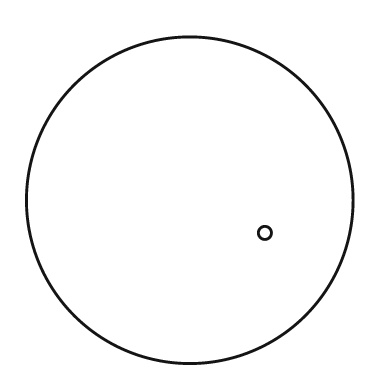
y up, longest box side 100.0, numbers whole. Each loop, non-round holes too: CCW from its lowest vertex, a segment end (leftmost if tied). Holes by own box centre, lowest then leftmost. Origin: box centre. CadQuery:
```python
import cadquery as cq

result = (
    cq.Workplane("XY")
    .moveTo(0.0, 0.0)
    .circle(50.0)
    .moveTo(23.0, -10.0)
    .circle(2.0)
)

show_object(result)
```